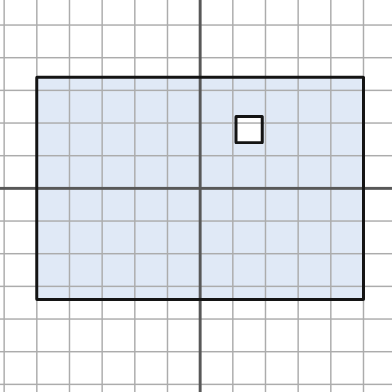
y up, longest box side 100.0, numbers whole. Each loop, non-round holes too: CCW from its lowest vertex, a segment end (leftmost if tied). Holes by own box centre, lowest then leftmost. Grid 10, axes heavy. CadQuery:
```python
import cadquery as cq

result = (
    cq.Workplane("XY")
    .moveTo(-50.0, -34.0)
    .lineTo(50.0, -34.0)
    .lineTo(50.0, 34.0)
    .lineTo(-50.0, 34.0)
    .close()
    .moveTo(11.0, 14.0)
    .lineTo(19.0, 14.0)
    .lineTo(19.0, 22.0)
    .lineTo(11.0, 22.0)
    .close()
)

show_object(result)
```